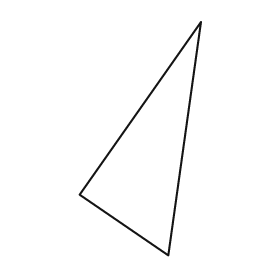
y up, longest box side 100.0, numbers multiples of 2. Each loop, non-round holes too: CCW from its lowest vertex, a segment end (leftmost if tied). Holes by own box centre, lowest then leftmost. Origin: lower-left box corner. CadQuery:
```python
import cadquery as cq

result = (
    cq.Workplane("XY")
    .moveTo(38.0, 0.0)
    .lineTo(52.0, 100.0)
    .lineTo(0.0, 26.0)
    .close()
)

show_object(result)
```